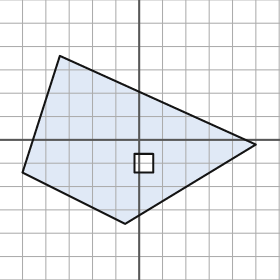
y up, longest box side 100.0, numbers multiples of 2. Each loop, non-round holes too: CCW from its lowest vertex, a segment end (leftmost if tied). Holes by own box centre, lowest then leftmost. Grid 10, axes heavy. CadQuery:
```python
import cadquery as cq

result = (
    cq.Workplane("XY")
    .moveTo(-6.0, -36.0)
    .lineTo(50.0, -2.0)
    .lineTo(-34.0, 36.0)
    .lineTo(-50.0, -14.0)
    .close()
    .moveTo(-2.0, -14.0)
    .lineTo(6.0, -14.0)
    .lineTo(6.0, -6.0)
    .lineTo(-2.0, -6.0)
    .close()
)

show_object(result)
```